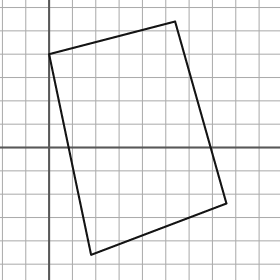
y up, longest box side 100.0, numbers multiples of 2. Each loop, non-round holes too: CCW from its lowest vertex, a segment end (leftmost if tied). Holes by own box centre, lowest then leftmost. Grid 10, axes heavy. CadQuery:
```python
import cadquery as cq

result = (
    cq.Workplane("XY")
    .moveTo(18.0, -46.0)
    .lineTo(76.0, -24.0)
    .lineTo(54.0, 54.0)
    .lineTo(0.0, 40.0)
    .close()
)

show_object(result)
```